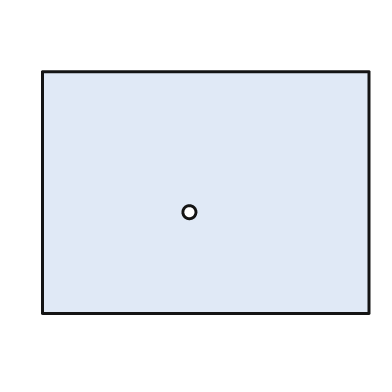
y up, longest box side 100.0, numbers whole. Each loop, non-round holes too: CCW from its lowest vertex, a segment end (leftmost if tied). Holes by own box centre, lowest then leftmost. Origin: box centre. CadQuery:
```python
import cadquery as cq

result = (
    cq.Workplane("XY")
    .moveTo(-50.0, -37.0)
    .lineTo(50.0, -37.0)
    .lineTo(50.0, 37.0)
    .lineTo(-50.0, 37.0)
    .close()
    .moveTo(-5.0, -6.0)
    .circle(2.0)
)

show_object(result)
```